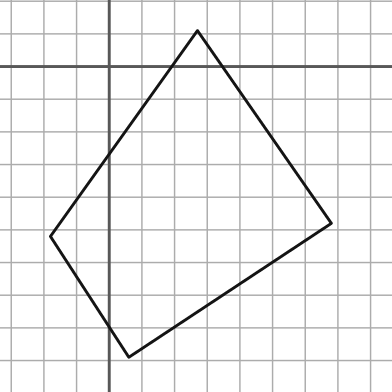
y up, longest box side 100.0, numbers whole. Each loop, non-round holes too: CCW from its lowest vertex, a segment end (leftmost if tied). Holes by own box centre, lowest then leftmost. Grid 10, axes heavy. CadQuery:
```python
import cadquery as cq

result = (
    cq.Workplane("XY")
    .moveTo(6.0, -89.0)
    .lineTo(68.0, -48.0)
    .lineTo(27.0, 11.0)
    .lineTo(-18.0, -52.0)
    .close()
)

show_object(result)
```